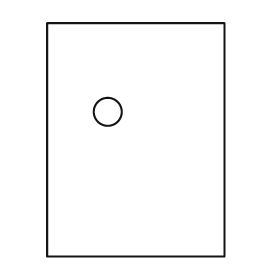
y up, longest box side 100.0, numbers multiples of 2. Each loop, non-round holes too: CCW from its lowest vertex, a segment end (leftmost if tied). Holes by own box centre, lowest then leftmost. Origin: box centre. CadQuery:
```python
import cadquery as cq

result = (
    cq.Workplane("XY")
    .moveTo(-38.0, -50.0)
    .lineTo(38.0, -50.0)
    .lineTo(38.0, 50.0)
    .lineTo(-38.0, 50.0)
    .close()
    .moveTo(-12.0, 12.0)
    .circle(6.0)
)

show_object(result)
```